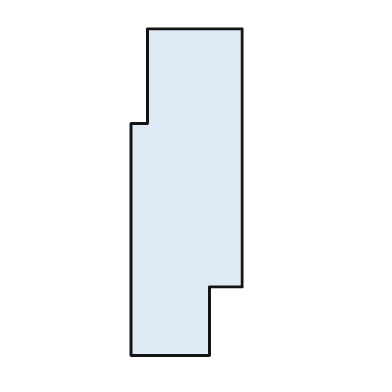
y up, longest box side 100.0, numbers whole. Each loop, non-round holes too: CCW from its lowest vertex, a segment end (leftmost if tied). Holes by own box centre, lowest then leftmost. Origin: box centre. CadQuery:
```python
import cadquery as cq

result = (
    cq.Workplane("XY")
    .moveTo(-17.0, -50.0)
    .lineTo(7.0, -50.0)
    .lineTo(7.0, -29.0)
    .lineTo(17.0, -29.0)
    .lineTo(17.0, 50.0)
    .lineTo(-12.0, 50.0)
    .lineTo(-12.0, 21.0)
    .lineTo(-17.0, 21.0)
    .close()
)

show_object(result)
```